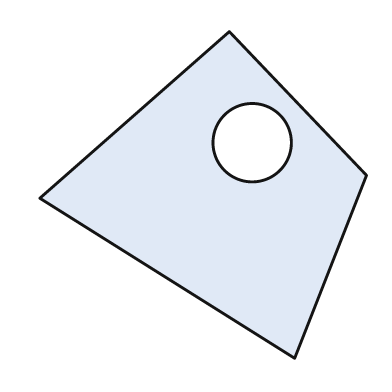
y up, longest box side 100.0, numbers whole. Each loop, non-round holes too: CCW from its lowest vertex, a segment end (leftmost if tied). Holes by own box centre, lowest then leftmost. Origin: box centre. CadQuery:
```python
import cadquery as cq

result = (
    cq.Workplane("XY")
    .moveTo(28.0, -50.0)
    .lineTo(50.0, 6.0)
    .lineTo(8.0, 50.0)
    .lineTo(-50.0, -1.0)
    .close()
    .moveTo(15.0, 16.0)
    .circle(12.0)
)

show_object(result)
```